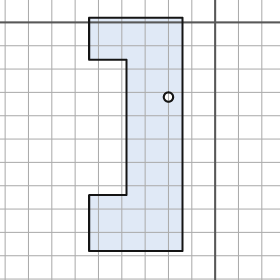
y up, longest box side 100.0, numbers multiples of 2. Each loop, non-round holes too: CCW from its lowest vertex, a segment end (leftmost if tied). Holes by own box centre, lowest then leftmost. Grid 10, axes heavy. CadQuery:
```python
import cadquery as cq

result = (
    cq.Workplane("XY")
    .moveTo(-54.0, -98.0)
    .lineTo(-14.0, -98.0)
    .lineTo(-14.0, 2.0)
    .lineTo(-54.0, 2.0)
    .lineTo(-54.0, -16.0)
    .lineTo(-38.0, -16.0)
    .lineTo(-38.0, -74.0)
    .lineTo(-54.0, -74.0)
    .close()
    .moveTo(-20.0, -32.0)
    .circle(2.0)
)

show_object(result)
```